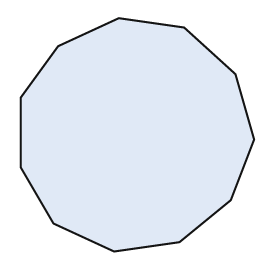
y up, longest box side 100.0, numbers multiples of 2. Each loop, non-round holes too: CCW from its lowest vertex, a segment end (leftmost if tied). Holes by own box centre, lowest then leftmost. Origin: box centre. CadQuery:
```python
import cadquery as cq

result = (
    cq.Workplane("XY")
    .moveTo(-10.0, -50.0)
    .lineTo(18.0, -46.0)
    .lineTo(40.0, -28.0)
    .lineTo(50.0, -2.0)
    .lineTo(42.0, 26.0)
    .lineTo(20.0, 46.0)
    .lineTo(-8.0, 50.0)
    .lineTo(-34.0, 38.0)
    .lineTo(-50.0, 16.0)
    .lineTo(-50.0, -14.0)
    .lineTo(-36.0, -38.0)
    .close()
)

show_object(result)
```